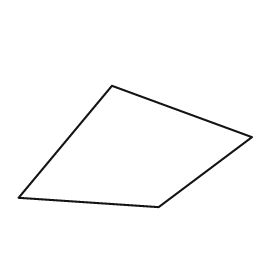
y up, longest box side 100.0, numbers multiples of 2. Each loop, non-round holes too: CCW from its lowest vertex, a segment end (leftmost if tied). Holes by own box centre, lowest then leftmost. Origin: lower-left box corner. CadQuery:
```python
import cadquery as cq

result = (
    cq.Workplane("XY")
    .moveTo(60.0, 0.0)
    .lineTo(100.0, 30.0)
    .lineTo(40.0, 52.0)
    .lineTo(0.0, 4.0)
    .close()
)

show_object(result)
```